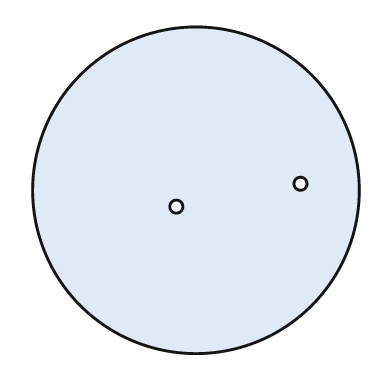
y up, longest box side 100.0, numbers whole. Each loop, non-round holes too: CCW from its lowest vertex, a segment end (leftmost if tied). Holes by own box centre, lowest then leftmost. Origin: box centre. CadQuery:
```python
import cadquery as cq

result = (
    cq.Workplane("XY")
    .moveTo(0.0, 0.0)
    .circle(50.0)
    .moveTo(-6.0, -5.0)
    .circle(2.0)
    .moveTo(32.0, 2.0)
    .circle(2.0)
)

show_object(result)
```